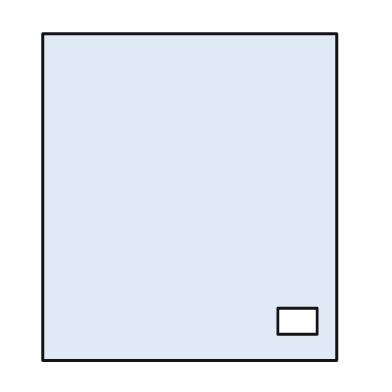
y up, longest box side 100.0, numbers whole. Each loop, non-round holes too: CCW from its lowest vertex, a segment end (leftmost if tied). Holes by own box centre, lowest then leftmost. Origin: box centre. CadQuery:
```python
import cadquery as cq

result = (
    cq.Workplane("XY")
    .moveTo(-45.0, -50.0)
    .lineTo(45.0, -50.0)
    .lineTo(45.0, 50.0)
    .lineTo(-45.0, 50.0)
    .close()
    .moveTo(27.0, -42.0)
    .lineTo(39.0, -42.0)
    .lineTo(39.0, -34.0)
    .lineTo(27.0, -34.0)
    .close()
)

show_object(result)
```